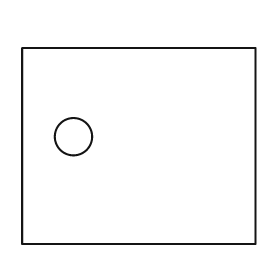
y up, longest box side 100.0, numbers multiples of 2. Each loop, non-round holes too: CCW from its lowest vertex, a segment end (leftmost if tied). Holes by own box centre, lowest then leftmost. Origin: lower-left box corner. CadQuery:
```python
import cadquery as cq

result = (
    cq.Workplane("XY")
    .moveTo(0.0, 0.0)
    .lineTo(100.0, 0.0)
    .lineTo(100.0, 84.0)
    .lineTo(0.0, 84.0)
    .close()
    .moveTo(22.0, 46.0)
    .circle(8.0)
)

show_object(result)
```